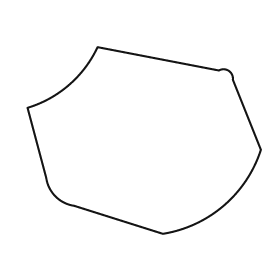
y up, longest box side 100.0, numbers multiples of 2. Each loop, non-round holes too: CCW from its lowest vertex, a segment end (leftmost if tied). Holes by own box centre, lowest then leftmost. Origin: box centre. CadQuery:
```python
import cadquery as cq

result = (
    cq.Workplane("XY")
    .moveTo(8.0, -40.0)
    .threePointArc((34.0, -28.0), (50.0, -4.0))
    .lineTo(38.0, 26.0)
    .threePointArc((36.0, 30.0), (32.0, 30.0))
    .lineTo(-20.0, 40.0)
    .threePointArc((-32.0, 24.0), (-50.0, 14.0))
    .lineTo(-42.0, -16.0)
    .threePointArc((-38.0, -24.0), (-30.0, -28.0))
    .close()
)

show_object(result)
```